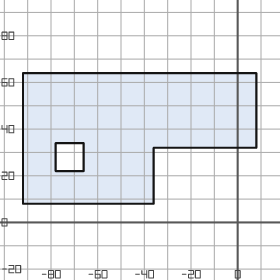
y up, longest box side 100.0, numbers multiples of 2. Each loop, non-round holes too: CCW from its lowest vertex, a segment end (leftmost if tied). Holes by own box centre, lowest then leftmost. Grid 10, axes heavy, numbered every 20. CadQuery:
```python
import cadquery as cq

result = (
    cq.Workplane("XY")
    .moveTo(-92.0, 8.0)
    .lineTo(-36.0, 8.0)
    .lineTo(-36.0, 32.0)
    .lineTo(8.0, 32.0)
    .lineTo(8.0, 64.0)
    .lineTo(-92.0, 64.0)
    .close()
    .moveTo(-78.0, 22.0)
    .lineTo(-66.0, 22.0)
    .lineTo(-66.0, 34.0)
    .lineTo(-78.0, 34.0)
    .close()
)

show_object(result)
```